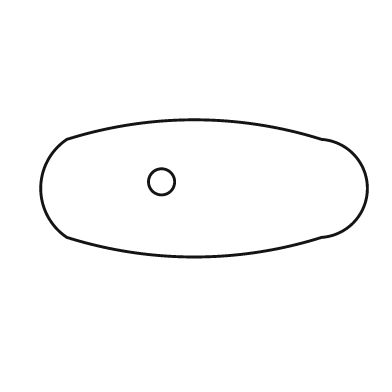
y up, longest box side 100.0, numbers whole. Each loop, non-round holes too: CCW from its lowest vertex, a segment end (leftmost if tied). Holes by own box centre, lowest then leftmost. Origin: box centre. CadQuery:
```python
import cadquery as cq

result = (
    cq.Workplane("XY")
    .moveTo(-42.0, -15.0)
    .threePointArc((-3.0, -21.0), (36.0, -15.0))
    .threePointArc((50.0, 0.0), (36.0, 15.0))
    .threePointArc((-3.0, 21.0), (-42.0, 15.0))
    .threePointArc((-50.0, 0.0), (-42.0, -15.0))
    .close()
    .moveTo(-13.0, 2.0)
    .circle(4.0)
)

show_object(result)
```